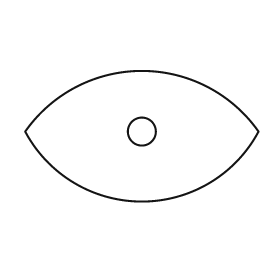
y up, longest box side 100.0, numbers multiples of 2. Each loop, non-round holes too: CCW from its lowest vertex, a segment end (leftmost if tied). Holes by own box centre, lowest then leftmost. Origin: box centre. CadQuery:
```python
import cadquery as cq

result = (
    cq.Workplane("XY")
    .moveTo(-50.0, 2.0)
    .threePointArc((0.0, -28.0), (50.0, 2.0))
    .threePointArc((0.0, 28.0), (-50.0, 2.0))
    .close()
    .moveTo(0.0, 2.0)
    .circle(6.0)
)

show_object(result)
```